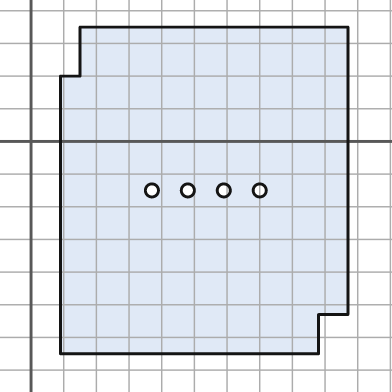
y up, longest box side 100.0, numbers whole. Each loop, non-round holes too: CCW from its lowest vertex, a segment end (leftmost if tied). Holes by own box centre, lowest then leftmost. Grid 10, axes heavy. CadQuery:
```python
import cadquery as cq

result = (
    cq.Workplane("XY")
    .moveTo(9.0, -65.0)
    .lineTo(88.0, -65.0)
    .lineTo(88.0, -53.0)
    .lineTo(97.0, -53.0)
    .lineTo(97.0, 35.0)
    .lineTo(15.0, 35.0)
    .lineTo(15.0, 20.0)
    .lineTo(9.0, 20.0)
    .close()
    .moveTo(37.0, -15.0)
    .circle(2.0)
    .moveTo(48.0, -15.0)
    .circle(2.0)
    .moveTo(59.0, -15.0)
    .circle(2.0)
    .moveTo(70.0, -15.0)
    .circle(2.0)
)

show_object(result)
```